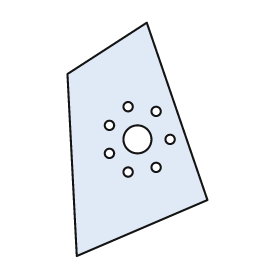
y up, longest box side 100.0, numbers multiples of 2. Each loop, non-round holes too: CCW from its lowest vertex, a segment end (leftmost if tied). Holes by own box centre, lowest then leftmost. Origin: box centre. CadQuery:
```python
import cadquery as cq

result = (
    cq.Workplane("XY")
    .moveTo(-26.0, -50.0)
    .lineTo(30.0, -26.0)
    .lineTo(4.0, 50.0)
    .lineTo(-30.0, 28.0)
    .close()
    .moveTo(-4.0, -14.0)
    .circle(2.0)
    .moveTo(8.0, -12.0)
    .circle(2.0)
    .moveTo(-12.0, -6.0)
    .circle(2.0)
    .moveTo(0.0, 0.0)
    .circle(6.0)
    .moveTo(14.0, 0.0)
    .circle(2.0)
    .moveTo(-12.0, 6.0)
    .circle(2.0)
    .moveTo(8.0, 12.0)
    .circle(2.0)
    .moveTo(-4.0, 14.0)
    .circle(2.0)
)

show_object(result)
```